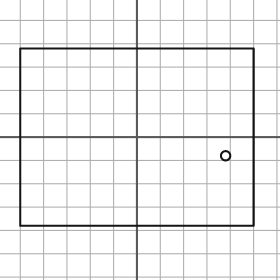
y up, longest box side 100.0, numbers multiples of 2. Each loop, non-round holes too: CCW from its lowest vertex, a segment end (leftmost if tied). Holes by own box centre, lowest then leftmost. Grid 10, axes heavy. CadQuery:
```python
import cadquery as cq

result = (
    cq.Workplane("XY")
    .moveTo(-50.0, -38.0)
    .lineTo(50.0, -38.0)
    .lineTo(50.0, 38.0)
    .lineTo(-50.0, 38.0)
    .close()
    .moveTo(38.0, -8.0)
    .circle(2.0)
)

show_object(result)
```